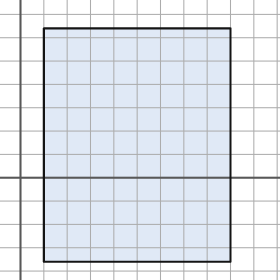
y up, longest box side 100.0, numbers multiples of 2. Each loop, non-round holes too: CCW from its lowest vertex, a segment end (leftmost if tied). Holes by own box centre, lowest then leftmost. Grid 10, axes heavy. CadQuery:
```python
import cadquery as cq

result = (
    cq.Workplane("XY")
    .moveTo(10.0, -36.0)
    .lineTo(90.0, -36.0)
    .lineTo(90.0, 64.0)
    .lineTo(10.0, 64.0)
    .close()
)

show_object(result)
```